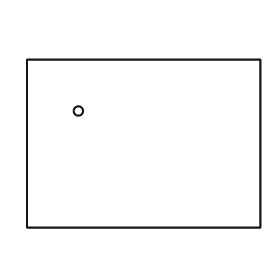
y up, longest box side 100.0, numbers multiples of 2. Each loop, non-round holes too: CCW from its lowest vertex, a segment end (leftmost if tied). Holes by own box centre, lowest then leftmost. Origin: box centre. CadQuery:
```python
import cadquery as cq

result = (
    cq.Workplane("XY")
    .moveTo(-50.0, -36.0)
    .lineTo(50.0, -36.0)
    .lineTo(50.0, 36.0)
    .lineTo(-50.0, 36.0)
    .close()
    .moveTo(-28.0, 14.0)
    .circle(2.0)
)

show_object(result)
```